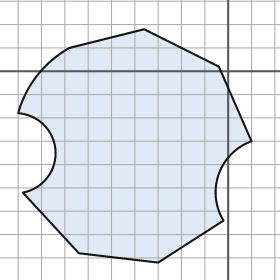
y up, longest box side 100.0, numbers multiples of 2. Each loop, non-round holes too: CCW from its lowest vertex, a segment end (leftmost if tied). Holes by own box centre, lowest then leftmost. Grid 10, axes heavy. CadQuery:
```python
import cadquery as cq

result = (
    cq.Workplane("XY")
    .moveTo(-30.0, -82.0)
    .lineTo(-2.0, -64.0)
    .threePointArc((-4.0, -44.0), (10.0, -30.0))
    .lineTo(-4.0, 2.0)
    .lineTo(-36.0, 18.0)
    .lineTo(-68.0, 10.0)
    .threePointArc((-82.0, -2.0), (-90.0, -18.0))
    .threePointArc((-74.0, -34.0), (-88.0, -52.0))
    .lineTo(-64.0, -78.0)
    .close()
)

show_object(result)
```